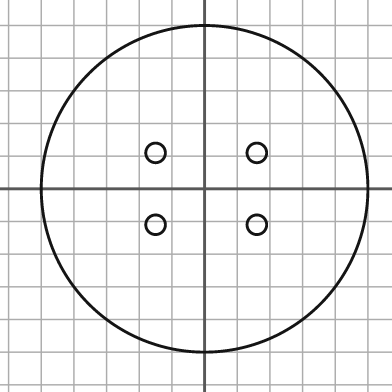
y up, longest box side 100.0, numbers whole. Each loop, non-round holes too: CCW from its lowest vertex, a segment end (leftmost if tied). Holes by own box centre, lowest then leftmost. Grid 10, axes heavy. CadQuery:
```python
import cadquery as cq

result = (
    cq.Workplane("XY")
    .moveTo(0.0, 0.0)
    .circle(50.0)
    .moveTo(-15.0, -11.0)
    .circle(3.0)
    .moveTo(16.0, -11.0)
    .circle(3.0)
    .moveTo(-15.0, 11.0)
    .circle(3.0)
    .moveTo(16.0, 11.0)
    .circle(3.0)
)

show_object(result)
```